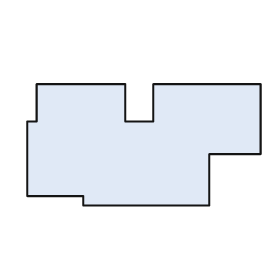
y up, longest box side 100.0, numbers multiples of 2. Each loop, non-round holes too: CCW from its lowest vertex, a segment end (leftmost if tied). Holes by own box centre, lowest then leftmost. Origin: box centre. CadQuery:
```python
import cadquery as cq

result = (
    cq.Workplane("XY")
    .moveTo(-26.0, -26.0)
    .lineTo(28.0, -26.0)
    .lineTo(28.0, -4.0)
    .lineTo(50.0, -4.0)
    .lineTo(50.0, 26.0)
    .lineTo(4.0, 26.0)
    .lineTo(4.0, 10.0)
    .lineTo(-8.0, 10.0)
    .lineTo(-8.0, 26.0)
    .lineTo(-46.0, 26.0)
    .lineTo(-46.0, 10.0)
    .lineTo(-50.0, 10.0)
    .lineTo(-50.0, -22.0)
    .lineTo(-26.0, -22.0)
    .close()
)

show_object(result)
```